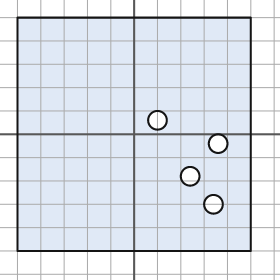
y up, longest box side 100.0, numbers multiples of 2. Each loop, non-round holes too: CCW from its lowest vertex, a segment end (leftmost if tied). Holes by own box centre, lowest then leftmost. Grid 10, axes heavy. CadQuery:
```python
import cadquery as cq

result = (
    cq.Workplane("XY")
    .moveTo(-50.0, -50.0)
    .lineTo(50.0, -50.0)
    .lineTo(50.0, 50.0)
    .lineTo(-50.0, 50.0)
    .close()
    .moveTo(34.0, -30.0)
    .circle(4.0)
    .moveTo(24.0, -18.0)
    .circle(4.0)
    .moveTo(36.0, -4.0)
    .circle(4.0)
    .moveTo(10.0, 6.0)
    .circle(4.0)
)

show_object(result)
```